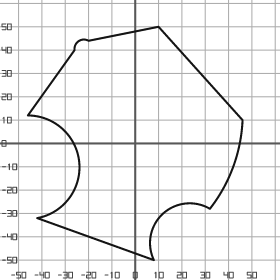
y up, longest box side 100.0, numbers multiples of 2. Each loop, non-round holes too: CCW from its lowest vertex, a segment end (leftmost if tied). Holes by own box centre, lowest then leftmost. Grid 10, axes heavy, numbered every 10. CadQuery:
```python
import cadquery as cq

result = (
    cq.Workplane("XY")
    .moveTo(8.0, -50.0)
    .threePointArc((12.0, -30.0), (32.0, -28.0))
    .threePointArc((42.0, -10.0), (46.0, 10.0))
    .lineTo(10.0, 50.0)
    .lineTo(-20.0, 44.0)
    .threePointArc((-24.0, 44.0), (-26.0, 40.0))
    .lineTo(-46.0, 12.0)
    .threePointArc((-24.0, -8.0), (-42.0, -32.0))
    .close()
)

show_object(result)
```